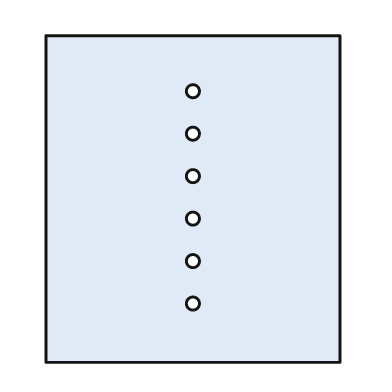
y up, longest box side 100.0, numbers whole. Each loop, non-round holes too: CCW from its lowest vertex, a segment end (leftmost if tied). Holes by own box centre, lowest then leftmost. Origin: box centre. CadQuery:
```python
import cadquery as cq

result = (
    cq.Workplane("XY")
    .moveTo(-45.0, -50.0)
    .lineTo(45.0, -50.0)
    .lineTo(45.0, 50.0)
    .lineTo(-45.0, 50.0)
    .close()
    .moveTo(0.0, -32.0)
    .circle(2.0)
    .moveTo(0.0, -19.0)
    .circle(2.0)
    .moveTo(0.0, -6.0)
    .circle(2.0)
    .moveTo(0.0, 7.0)
    .circle(2.0)
    .moveTo(0.0, 20.0)
    .circle(2.0)
    .moveTo(0.0, 33.0)
    .circle(2.0)
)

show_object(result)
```